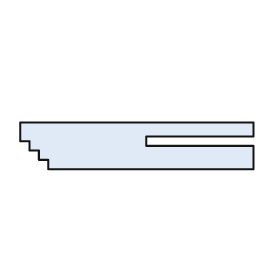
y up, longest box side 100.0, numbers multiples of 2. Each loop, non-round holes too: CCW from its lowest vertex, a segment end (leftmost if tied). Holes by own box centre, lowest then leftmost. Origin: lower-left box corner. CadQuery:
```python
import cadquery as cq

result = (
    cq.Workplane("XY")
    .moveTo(12.0, 0.0)
    .lineTo(100.0, 0.0)
    .lineTo(100.0, 10.0)
    .lineTo(54.0, 10.0)
    .lineTo(54.0, 14.0)
    .lineTo(100.0, 14.0)
    .lineTo(100.0, 20.0)
    .lineTo(0.0, 20.0)
    .lineTo(0.0, 12.0)
    .lineTo(4.0, 12.0)
    .lineTo(4.0, 8.0)
    .lineTo(8.0, 8.0)
    .lineTo(8.0, 4.0)
    .lineTo(12.0, 4.0)
    .close()
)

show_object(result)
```